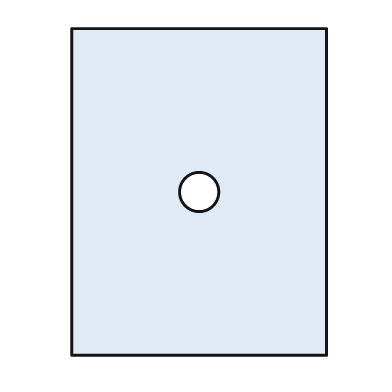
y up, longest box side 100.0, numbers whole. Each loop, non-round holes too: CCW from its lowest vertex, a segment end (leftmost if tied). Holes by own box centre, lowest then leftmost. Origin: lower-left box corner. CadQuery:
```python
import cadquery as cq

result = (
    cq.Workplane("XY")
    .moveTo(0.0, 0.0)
    .lineTo(78.0, 0.0)
    .lineTo(78.0, 100.0)
    .lineTo(0.0, 100.0)
    .close()
    .moveTo(39.0, 50.0)
    .circle(6.0)
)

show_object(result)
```